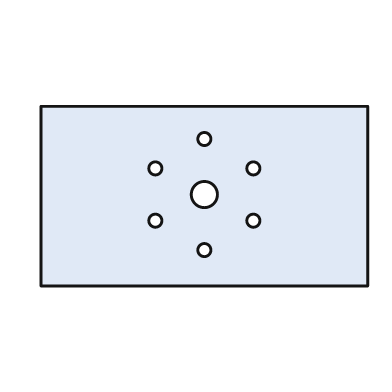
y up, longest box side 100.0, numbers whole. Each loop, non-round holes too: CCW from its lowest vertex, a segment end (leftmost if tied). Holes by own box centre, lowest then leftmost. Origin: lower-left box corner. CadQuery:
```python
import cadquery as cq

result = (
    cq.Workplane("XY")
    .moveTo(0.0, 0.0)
    .lineTo(100.0, 0.0)
    .lineTo(100.0, 55.0)
    .lineTo(0.0, 55.0)
    .close()
    .moveTo(50.0, 11.0)
    .circle(2.0)
    .moveTo(35.0, 20.0)
    .circle(2.0)
    .moveTo(65.0, 20.0)
    .circle(2.0)
    .moveTo(50.0, 28.0)
    .circle(4.0)
    .moveTo(35.0, 36.0)
    .circle(2.0)
    .moveTo(65.0, 36.0)
    .circle(2.0)
    .moveTo(50.0, 45.0)
    .circle(2.0)
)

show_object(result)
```